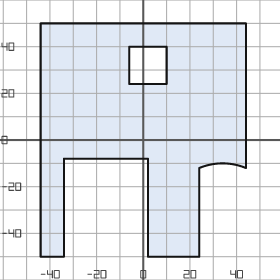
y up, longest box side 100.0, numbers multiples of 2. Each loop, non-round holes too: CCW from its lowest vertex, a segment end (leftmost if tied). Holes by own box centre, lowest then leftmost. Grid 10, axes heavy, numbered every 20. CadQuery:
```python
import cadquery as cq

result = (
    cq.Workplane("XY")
    .moveTo(-44.0, -50.0)
    .lineTo(-34.0, -50.0)
    .lineTo(-34.0, -8.0)
    .lineTo(2.0, -8.0)
    .lineTo(2.0, -50.0)
    .lineTo(24.0, -50.0)
    .lineTo(24.0, -12.0)
    .threePointArc((34.0, -10.0), (44.0, -12.0))
    .lineTo(44.0, 50.0)
    .lineTo(-44.0, 50.0)
    .close()
    .moveTo(-6.0, 24.0)
    .lineTo(10.0, 24.0)
    .lineTo(10.0, 40.0)
    .lineTo(-6.0, 40.0)
    .close()
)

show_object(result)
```